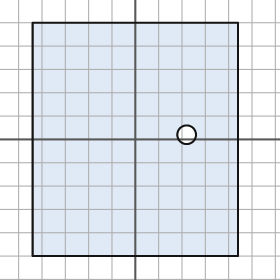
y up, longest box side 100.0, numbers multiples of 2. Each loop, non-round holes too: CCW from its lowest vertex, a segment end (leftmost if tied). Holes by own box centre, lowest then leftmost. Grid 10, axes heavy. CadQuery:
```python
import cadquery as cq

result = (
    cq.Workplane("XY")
    .moveTo(-44.0, -50.0)
    .lineTo(44.0, -50.0)
    .lineTo(44.0, 50.0)
    .lineTo(-44.0, 50.0)
    .close()
    .moveTo(22.0, 2.0)
    .circle(4.0)
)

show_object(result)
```